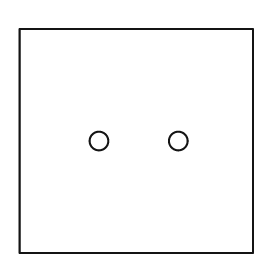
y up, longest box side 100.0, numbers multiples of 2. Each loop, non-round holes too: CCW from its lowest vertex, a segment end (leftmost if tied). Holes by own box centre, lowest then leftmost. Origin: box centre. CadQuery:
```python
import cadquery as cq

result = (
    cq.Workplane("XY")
    .moveTo(-50.0, -48.0)
    .lineTo(50.0, -48.0)
    .lineTo(50.0, 48.0)
    .lineTo(-50.0, 48.0)
    .close()
    .moveTo(-16.0, 0.0)
    .circle(4.0)
    .moveTo(18.0, 0.0)
    .circle(4.0)
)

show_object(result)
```